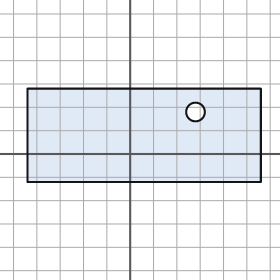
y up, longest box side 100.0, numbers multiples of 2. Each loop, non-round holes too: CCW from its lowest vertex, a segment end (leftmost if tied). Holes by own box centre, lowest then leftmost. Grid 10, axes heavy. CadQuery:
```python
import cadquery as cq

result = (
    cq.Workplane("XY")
    .moveTo(-44.0, -12.0)
    .lineTo(56.0, -12.0)
    .lineTo(56.0, 28.0)
    .lineTo(-44.0, 28.0)
    .close()
    .moveTo(28.0, 18.0)
    .circle(4.0)
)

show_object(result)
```